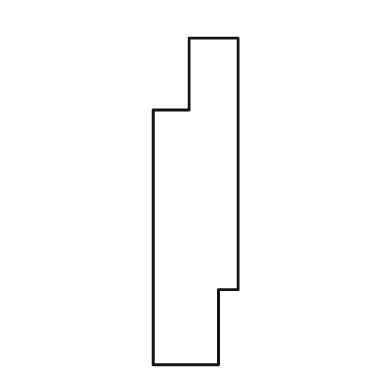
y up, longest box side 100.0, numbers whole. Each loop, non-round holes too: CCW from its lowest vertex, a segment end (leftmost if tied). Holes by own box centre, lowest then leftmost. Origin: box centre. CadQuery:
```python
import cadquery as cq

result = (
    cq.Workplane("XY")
    .moveTo(-13.0, -50.0)
    .lineTo(7.0, -50.0)
    .lineTo(7.0, -27.0)
    .lineTo(13.0, -27.0)
    .lineTo(13.0, 50.0)
    .lineTo(-2.0, 50.0)
    .lineTo(-2.0, 28.0)
    .lineTo(-13.0, 28.0)
    .close()
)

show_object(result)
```